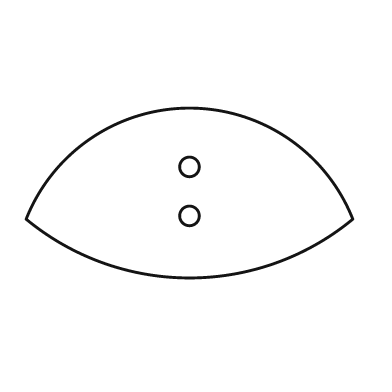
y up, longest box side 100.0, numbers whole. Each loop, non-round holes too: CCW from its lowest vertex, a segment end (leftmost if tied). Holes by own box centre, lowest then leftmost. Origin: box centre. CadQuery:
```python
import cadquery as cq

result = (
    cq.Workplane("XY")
    .moveTo(-50.0, -8.0)
    .threePointArc((0.0, -26.0), (50.0, -8.0))
    .threePointArc((0.0, 26.0), (-50.0, -8.0))
    .close()
    .moveTo(0.0, -7.0)
    .circle(3.0)
    .moveTo(0.0, 8.0)
    .circle(3.0)
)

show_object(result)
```